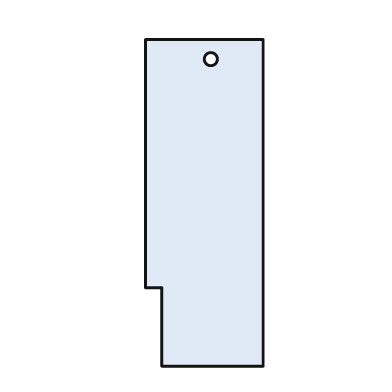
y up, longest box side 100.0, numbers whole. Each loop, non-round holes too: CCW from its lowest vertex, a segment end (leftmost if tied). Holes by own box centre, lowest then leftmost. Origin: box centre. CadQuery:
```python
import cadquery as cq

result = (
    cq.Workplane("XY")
    .moveTo(-13.0, -50.0)
    .lineTo(18.0, -50.0)
    .lineTo(18.0, 50.0)
    .lineTo(-18.0, 50.0)
    .lineTo(-18.0, -26.0)
    .lineTo(-13.0, -26.0)
    .close()
    .moveTo(2.0, 44.0)
    .circle(2.0)
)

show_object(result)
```